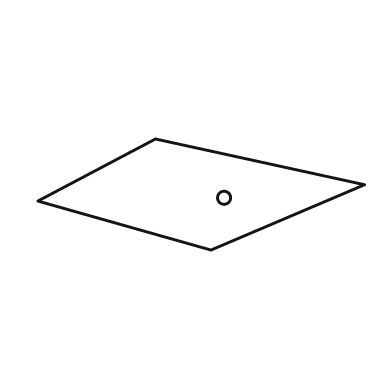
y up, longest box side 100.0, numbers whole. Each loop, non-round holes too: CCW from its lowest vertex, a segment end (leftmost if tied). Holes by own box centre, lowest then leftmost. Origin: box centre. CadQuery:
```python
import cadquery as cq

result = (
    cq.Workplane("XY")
    .moveTo(3.0, -17.0)
    .lineTo(50.0, 3.0)
    .lineTo(-14.0, 17.0)
    .lineTo(-50.0, -2.0)
    .close()
    .moveTo(7.0, -1.0)
    .circle(2.0)
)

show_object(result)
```